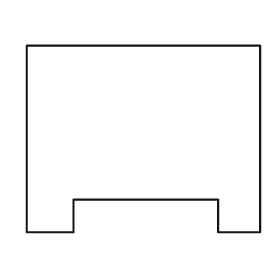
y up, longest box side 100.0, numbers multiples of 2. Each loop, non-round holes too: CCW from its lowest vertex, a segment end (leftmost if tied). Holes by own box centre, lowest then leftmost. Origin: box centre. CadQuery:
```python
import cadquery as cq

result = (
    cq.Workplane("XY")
    .moveTo(-50.0, -40.0)
    .lineTo(-30.0, -40.0)
    .lineTo(-30.0, -26.0)
    .lineTo(32.0, -26.0)
    .lineTo(32.0, -40.0)
    .lineTo(50.0, -40.0)
    .lineTo(50.0, 40.0)
    .lineTo(-50.0, 40.0)
    .close()
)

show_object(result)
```